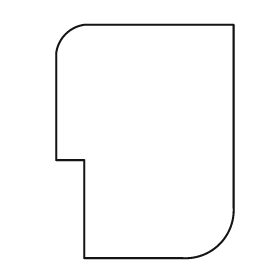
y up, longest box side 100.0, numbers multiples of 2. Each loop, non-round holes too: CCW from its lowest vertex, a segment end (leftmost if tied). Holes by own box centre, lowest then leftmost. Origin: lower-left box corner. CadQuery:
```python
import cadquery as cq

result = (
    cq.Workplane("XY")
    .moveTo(12.0, 0.0)
    .lineTo(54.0, 0.0)
    .threePointArc((70.0, 6.0), (76.0, 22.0))
    .lineTo(76.0, 100.0)
    .lineTo(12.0, 100.0)
    .threePointArc((4.0, 96.0), (0.0, 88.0))
    .lineTo(0.0, 42.0)
    .lineTo(12.0, 42.0)
    .close()
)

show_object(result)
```